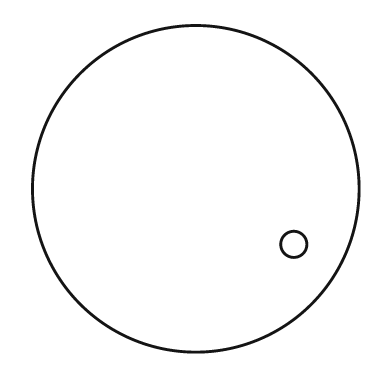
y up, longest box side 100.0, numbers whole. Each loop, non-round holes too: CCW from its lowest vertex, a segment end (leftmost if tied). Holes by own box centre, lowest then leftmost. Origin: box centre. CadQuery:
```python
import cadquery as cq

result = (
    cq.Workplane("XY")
    .moveTo(0.0, 0.0)
    .circle(50.0)
    .moveTo(30.0, -17.0)
    .circle(4.0)
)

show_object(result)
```